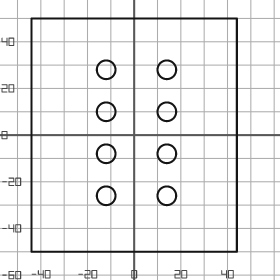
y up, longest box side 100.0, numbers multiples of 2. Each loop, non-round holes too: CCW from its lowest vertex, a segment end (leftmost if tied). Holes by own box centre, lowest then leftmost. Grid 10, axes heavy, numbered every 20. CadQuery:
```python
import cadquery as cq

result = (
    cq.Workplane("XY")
    .moveTo(-44.0, -50.0)
    .lineTo(44.0, -50.0)
    .lineTo(44.0, 50.0)
    .lineTo(-44.0, 50.0)
    .close()
    .moveTo(-12.0, -26.0)
    .circle(4.0)
    .moveTo(14.0, -26.0)
    .circle(4.0)
    .moveTo(-12.0, -8.0)
    .circle(4.0)
    .moveTo(14.0, -8.0)
    .circle(4.0)
    .moveTo(-12.0, 10.0)
    .circle(4.0)
    .moveTo(14.0, 10.0)
    .circle(4.0)
    .moveTo(-12.0, 28.0)
    .circle(4.0)
    .moveTo(14.0, 28.0)
    .circle(4.0)
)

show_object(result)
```